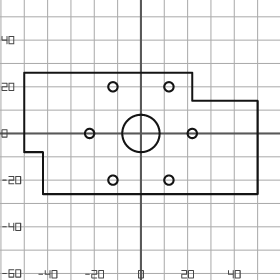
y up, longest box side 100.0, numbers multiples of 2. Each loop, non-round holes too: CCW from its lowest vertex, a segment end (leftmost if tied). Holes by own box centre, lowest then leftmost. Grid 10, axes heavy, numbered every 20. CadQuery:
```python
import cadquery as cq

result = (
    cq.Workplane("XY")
    .moveTo(-42.0, -26.0)
    .lineTo(50.0, -26.0)
    .lineTo(50.0, 14.0)
    .lineTo(22.0, 14.0)
    .lineTo(22.0, 26.0)
    .lineTo(-50.0, 26.0)
    .lineTo(-50.0, -8.0)
    .lineTo(-42.0, -8.0)
    .close()
    .moveTo(-12.0, -20.0)
    .circle(2.0)
    .moveTo(12.0, -20.0)
    .circle(2.0)
    .moveTo(-22.0, 0.0)
    .circle(2.0)
    .moveTo(0.0, 0.0)
    .circle(8.0)
    .moveTo(22.0, 0.0)
    .circle(2.0)
    .moveTo(-12.0, 20.0)
    .circle(2.0)
    .moveTo(12.0, 20.0)
    .circle(2.0)
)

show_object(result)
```